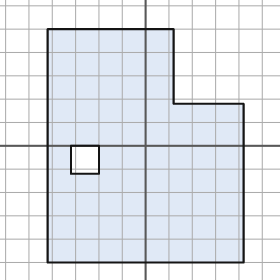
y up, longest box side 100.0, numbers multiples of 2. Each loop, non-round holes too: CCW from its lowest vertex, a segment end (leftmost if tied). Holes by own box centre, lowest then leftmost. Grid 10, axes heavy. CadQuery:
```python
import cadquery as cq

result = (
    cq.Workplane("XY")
    .moveTo(-42.0, -50.0)
    .lineTo(42.0, -50.0)
    .lineTo(42.0, 18.0)
    .lineTo(12.0, 18.0)
    .lineTo(12.0, 50.0)
    .lineTo(-42.0, 50.0)
    .close()
    .moveTo(-32.0, -12.0)
    .lineTo(-20.0, -12.0)
    .lineTo(-20.0, 0.0)
    .lineTo(-32.0, 0.0)
    .close()
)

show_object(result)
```